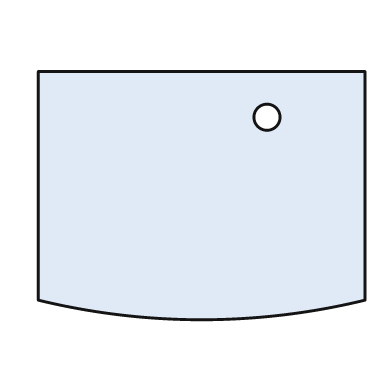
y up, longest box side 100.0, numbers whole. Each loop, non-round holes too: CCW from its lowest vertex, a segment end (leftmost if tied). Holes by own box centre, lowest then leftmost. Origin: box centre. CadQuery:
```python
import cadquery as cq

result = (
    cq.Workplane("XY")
    .moveTo(-50.0, -32.0)
    .threePointArc((0.0, -38.0), (50.0, -32.0))
    .lineTo(50.0, 38.0)
    .lineTo(-50.0, 38.0)
    .close()
    .moveTo(20.0, 24.0)
    .circle(4.0)
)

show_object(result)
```